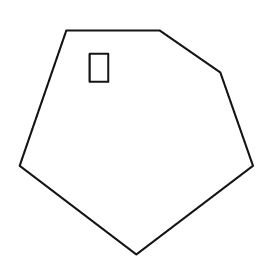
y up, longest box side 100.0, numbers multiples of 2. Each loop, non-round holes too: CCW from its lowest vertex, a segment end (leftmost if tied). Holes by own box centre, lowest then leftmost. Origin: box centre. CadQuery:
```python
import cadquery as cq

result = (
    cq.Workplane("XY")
    .moveTo(0.0, -48.0)
    .lineTo(50.0, -10.0)
    .lineTo(36.0, 30.0)
    .lineTo(10.0, 48.0)
    .lineTo(-30.0, 48.0)
    .lineTo(-50.0, -10.0)
    .close()
    .moveTo(-20.0, 26.0)
    .lineTo(-12.0, 26.0)
    .lineTo(-12.0, 38.0)
    .lineTo(-20.0, 38.0)
    .close()
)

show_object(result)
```